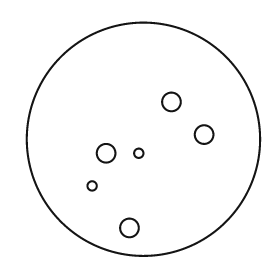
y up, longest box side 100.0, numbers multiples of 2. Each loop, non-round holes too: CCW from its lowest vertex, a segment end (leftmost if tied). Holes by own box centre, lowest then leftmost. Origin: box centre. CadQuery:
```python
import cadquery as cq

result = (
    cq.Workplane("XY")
    .moveTo(0.0, 0.0)
    .circle(50.0)
    .moveTo(-6.0, -38.0)
    .circle(4.0)
    .moveTo(-22.0, -20.0)
    .circle(2.0)
    .moveTo(-16.0, -6.0)
    .circle(4.0)
    .moveTo(-2.0, -6.0)
    .circle(2.0)
    .moveTo(26.0, 2.0)
    .circle(4.0)
    .moveTo(12.0, 16.0)
    .circle(4.0)
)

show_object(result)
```